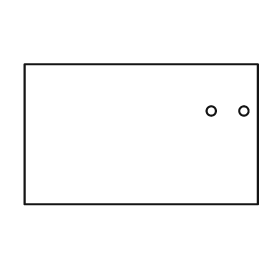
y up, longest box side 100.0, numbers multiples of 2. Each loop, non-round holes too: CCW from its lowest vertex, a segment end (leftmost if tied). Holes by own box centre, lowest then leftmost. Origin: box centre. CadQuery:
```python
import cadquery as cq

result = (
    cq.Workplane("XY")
    .moveTo(-50.0, -30.0)
    .lineTo(50.0, -30.0)
    .lineTo(50.0, 30.0)
    .lineTo(-50.0, 30.0)
    .close()
    .moveTo(30.0, 10.0)
    .circle(2.0)
    .moveTo(44.0, 10.0)
    .circle(2.0)
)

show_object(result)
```